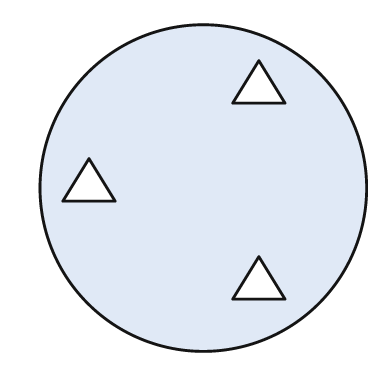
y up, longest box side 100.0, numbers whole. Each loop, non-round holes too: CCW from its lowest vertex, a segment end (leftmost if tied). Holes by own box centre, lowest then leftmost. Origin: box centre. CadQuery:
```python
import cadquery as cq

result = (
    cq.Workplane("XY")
    .moveTo(0.0, 0.0)
    .circle(50.0)
    .moveTo(9.0, -34.0)
    .lineTo(25.0, -34.0)
    .lineTo(17.0, -21.0)
    .close()
    .moveTo(-43.0, -4.0)
    .lineTo(-27.0, -4.0)
    .lineTo(-35.0, 9.0)
    .close()
    .moveTo(9.0, 26.0)
    .lineTo(25.0, 26.0)
    .lineTo(17.0, 39.0)
    .close()
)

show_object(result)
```